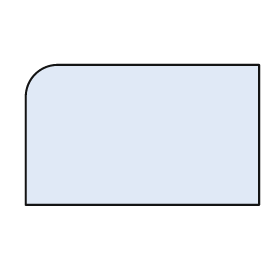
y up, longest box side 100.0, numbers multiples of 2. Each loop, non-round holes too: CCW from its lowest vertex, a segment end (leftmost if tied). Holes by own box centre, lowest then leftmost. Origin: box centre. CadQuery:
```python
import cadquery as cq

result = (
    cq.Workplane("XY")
    .moveTo(-50.0, -30.0)
    .lineTo(50.0, -30.0)
    .lineTo(50.0, 30.0)
    .lineTo(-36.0, 30.0)
    .threePointArc((-46.0, 26.0), (-50.0, 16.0))
    .close()
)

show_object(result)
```